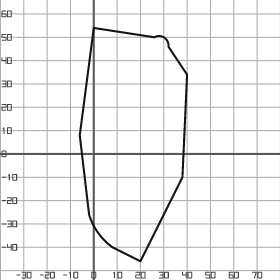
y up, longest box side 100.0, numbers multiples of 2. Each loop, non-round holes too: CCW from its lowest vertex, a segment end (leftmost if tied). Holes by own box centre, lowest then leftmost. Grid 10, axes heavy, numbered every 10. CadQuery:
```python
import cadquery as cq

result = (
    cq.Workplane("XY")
    .moveTo(20.0, -46.0)
    .lineTo(38.0, -10.0)
    .lineTo(40.0, 34.0)
    .lineTo(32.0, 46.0)
    .threePointArc((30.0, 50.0), (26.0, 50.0))
    .lineTo(0.0, 54.0)
    .lineTo(-6.0, 8.0)
    .lineTo(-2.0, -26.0)
    .threePointArc((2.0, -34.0), (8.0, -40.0))
    .close()
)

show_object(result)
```